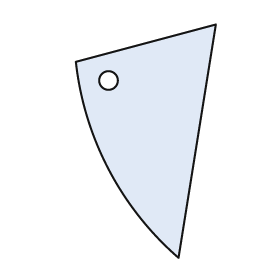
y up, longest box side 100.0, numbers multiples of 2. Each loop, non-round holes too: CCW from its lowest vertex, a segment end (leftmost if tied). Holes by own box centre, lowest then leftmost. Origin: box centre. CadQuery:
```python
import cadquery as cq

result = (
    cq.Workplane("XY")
    .moveTo(14.0, -50.0)
    .lineTo(30.0, 50.0)
    .lineTo(-30.0, 34.0)
    .threePointArc((-16.0, -12.0), (14.0, -50.0))
    .close()
    .moveTo(-16.0, 26.0)
    .circle(4.0)
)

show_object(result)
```